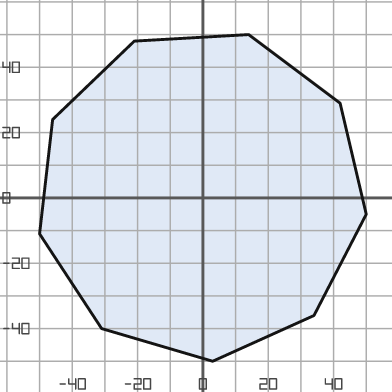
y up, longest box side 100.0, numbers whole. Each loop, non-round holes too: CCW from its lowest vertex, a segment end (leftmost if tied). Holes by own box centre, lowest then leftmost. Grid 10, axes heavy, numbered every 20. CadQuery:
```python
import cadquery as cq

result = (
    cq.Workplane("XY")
    .moveTo(3.0, -50.0)
    .lineTo(34.0, -36.0)
    .lineTo(50.0, -5.0)
    .lineTo(42.0, 29.0)
    .lineTo(14.0, 50.0)
    .lineTo(-21.0, 48.0)
    .lineTo(-46.0, 24.0)
    .lineTo(-50.0, -11.0)
    .lineTo(-31.0, -40.0)
    .close()
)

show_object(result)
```